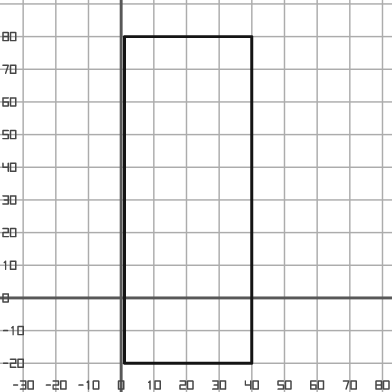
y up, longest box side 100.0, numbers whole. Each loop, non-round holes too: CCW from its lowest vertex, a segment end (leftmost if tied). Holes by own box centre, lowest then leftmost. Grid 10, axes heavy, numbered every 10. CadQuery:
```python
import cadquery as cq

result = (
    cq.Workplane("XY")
    .moveTo(1.0, -20.0)
    .lineTo(40.0, -20.0)
    .lineTo(40.0, 80.0)
    .lineTo(1.0, 80.0)
    .close()
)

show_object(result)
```